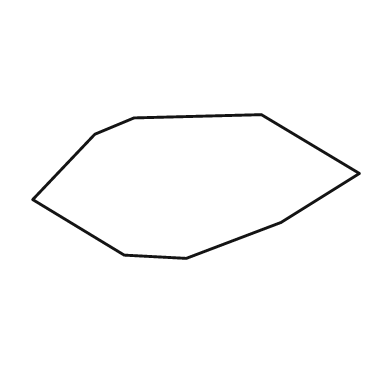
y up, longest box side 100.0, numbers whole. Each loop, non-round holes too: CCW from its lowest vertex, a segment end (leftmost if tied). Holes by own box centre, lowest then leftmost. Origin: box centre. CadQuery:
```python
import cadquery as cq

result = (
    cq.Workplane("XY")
    .moveTo(-3.0, -22.0)
    .lineTo(26.0, -11.0)
    .lineTo(50.0, 4.0)
    .lineTo(20.0, 22.0)
    .lineTo(-19.0, 21.0)
    .lineTo(-31.0, 16.0)
    .lineTo(-50.0, -4.0)
    .lineTo(-22.0, -21.0)
    .close()
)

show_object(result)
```